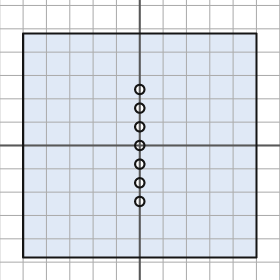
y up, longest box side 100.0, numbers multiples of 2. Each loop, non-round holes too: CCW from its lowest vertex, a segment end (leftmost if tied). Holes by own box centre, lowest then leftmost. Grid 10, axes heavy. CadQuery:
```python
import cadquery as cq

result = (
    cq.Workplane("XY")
    .moveTo(-50.0, -48.0)
    .lineTo(50.0, -48.0)
    .lineTo(50.0, 48.0)
    .lineTo(-50.0, 48.0)
    .close()
    .moveTo(0.0, -24.0)
    .circle(2.0)
    .moveTo(0.0, -16.0)
    .circle(2.0)
    .moveTo(0.0, -8.0)
    .circle(2.0)
    .moveTo(0.0, 0.0)
    .circle(2.0)
    .moveTo(0.0, 8.0)
    .circle(2.0)
    .moveTo(0.0, 16.0)
    .circle(2.0)
    .moveTo(0.0, 24.0)
    .circle(2.0)
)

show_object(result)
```